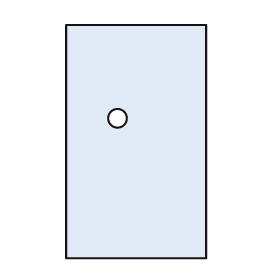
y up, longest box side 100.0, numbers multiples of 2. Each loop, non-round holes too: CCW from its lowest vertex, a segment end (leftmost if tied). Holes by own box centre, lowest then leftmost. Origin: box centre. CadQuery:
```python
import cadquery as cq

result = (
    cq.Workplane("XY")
    .moveTo(-30.0, -50.0)
    .lineTo(30.0, -50.0)
    .lineTo(30.0, 50.0)
    .lineTo(-30.0, 50.0)
    .close()
    .moveTo(-8.0, 10.0)
    .circle(4.0)
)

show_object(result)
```